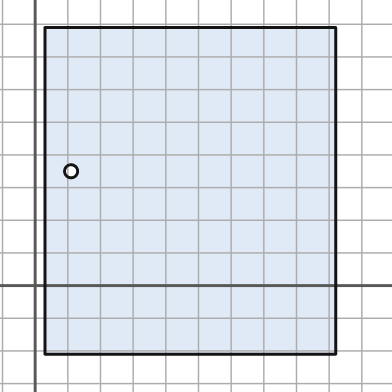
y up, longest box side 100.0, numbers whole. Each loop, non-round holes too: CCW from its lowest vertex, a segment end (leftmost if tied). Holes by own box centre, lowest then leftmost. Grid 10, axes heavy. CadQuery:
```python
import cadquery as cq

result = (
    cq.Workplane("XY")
    .moveTo(3.0, -21.0)
    .lineTo(92.0, -21.0)
    .lineTo(92.0, 79.0)
    .lineTo(3.0, 79.0)
    .close()
    .moveTo(11.0, 35.0)
    .circle(2.0)
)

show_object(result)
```